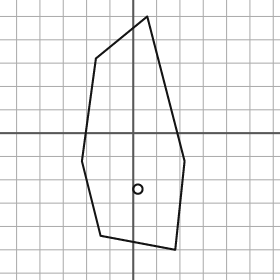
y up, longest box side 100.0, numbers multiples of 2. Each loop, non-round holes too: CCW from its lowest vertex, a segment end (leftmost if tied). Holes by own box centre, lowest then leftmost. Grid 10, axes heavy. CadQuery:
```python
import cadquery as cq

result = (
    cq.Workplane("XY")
    .moveTo(18.0, -50.0)
    .lineTo(22.0, -12.0)
    .lineTo(6.0, 50.0)
    .lineTo(-16.0, 32.0)
    .lineTo(-22.0, -12.0)
    .lineTo(-14.0, -44.0)
    .close()
    .moveTo(2.0, -24.0)
    .circle(2.0)
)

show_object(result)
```